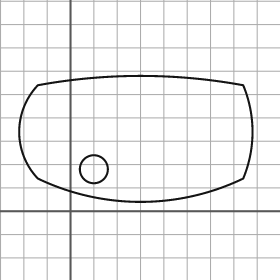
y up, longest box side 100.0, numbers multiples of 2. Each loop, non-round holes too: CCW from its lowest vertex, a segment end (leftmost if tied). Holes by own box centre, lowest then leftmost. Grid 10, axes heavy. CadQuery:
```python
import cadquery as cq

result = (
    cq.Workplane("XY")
    .moveTo(-14.0, 14.0)
    .threePointArc((30.0, 4.0), (74.0, 14.0))
    .threePointArc((78.0, 34.0), (74.0, 54.0))
    .threePointArc((30.0, 58.0), (-14.0, 54.0))
    .threePointArc((-22.0, 34.0), (-14.0, 14.0))
    .close()
    .moveTo(10.0, 18.0)
    .circle(6.0)
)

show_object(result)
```